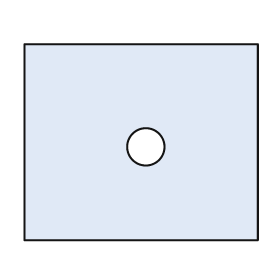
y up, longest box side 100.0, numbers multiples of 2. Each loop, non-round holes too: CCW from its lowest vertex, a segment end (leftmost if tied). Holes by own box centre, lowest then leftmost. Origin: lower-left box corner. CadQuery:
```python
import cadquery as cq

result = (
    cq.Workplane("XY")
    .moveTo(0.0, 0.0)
    .lineTo(100.0, 0.0)
    .lineTo(100.0, 84.0)
    .lineTo(0.0, 84.0)
    .close()
    .moveTo(52.0, 40.0)
    .circle(8.0)
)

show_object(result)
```